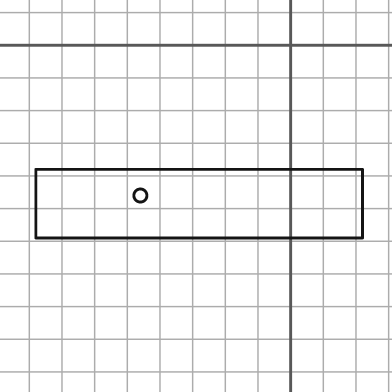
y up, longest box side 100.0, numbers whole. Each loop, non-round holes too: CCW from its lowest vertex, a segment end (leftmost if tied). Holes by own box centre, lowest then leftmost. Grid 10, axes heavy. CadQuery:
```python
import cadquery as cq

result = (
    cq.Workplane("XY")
    .moveTo(-78.0, -59.0)
    .lineTo(22.0, -59.0)
    .lineTo(22.0, -38.0)
    .lineTo(-78.0, -38.0)
    .close()
    .moveTo(-46.0, -46.0)
    .circle(2.0)
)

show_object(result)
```